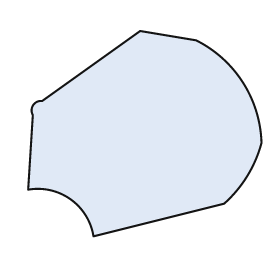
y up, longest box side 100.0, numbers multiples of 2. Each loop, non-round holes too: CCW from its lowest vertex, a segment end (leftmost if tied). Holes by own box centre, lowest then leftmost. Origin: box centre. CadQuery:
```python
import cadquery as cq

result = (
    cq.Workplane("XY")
    .moveTo(-22.0, -44.0)
    .lineTo(34.0, -30.0)
    .threePointArc((44.0, -18.0), (50.0, -4.0))
    .threePointArc((42.0, 22.0), (22.0, 40.0))
    .lineTo(-2.0, 44.0)
    .lineTo(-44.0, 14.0)
    .threePointArc((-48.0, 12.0), (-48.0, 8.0))
    .lineTo(-50.0, -24.0)
    .threePointArc((-32.0, -28.0), (-22.0, -44.0))
    .close()
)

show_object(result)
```